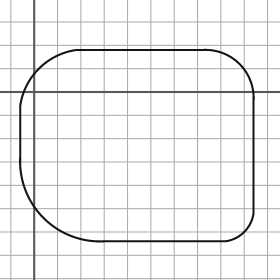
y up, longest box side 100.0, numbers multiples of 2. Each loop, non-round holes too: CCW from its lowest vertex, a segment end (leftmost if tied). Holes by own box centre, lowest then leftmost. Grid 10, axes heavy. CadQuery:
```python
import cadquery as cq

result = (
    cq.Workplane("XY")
    .moveTo(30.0, -64.0)
    .lineTo(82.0, -64.0)
    .threePointArc((90.0, -60.0), (94.0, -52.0))
    .lineTo(94.0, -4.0)
    .threePointArc((88.0, 12.0), (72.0, 18.0))
    .lineTo(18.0, 18.0)
    .threePointArc((2.0, 10.0), (-6.0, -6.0))
    .lineTo(-6.0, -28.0)
    .threePointArc((4.0, -54.0), (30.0, -64.0))
    .close()
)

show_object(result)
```